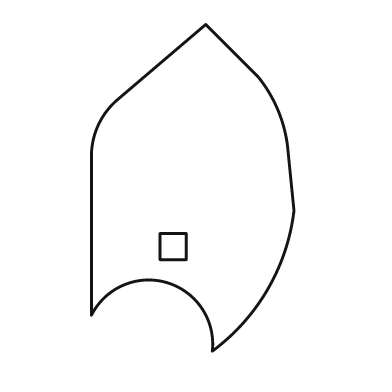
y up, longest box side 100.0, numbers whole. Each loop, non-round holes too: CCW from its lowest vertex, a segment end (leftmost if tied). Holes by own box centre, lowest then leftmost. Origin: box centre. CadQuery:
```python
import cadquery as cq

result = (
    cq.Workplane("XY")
    .moveTo(6.0, -50.0)
    .threePointArc((23.0, -31.0), (31.0, -7.0))
    .lineTo(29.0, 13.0)
    .threePointArc((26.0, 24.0), (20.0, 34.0))
    .lineTo(4.0, 50.0)
    .lineTo(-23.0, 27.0)
    .threePointArc((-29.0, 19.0), (-31.0, 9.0))
    .lineTo(-31.0, -39.0)
    .threePointArc((-8.0, -29.0), (6.0, -50.0))
    .close()
    .moveTo(-10.0, -22.0)
    .lineTo(-2.0, -22.0)
    .lineTo(-2.0, -14.0)
    .lineTo(-10.0, -14.0)
    .close()
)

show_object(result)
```